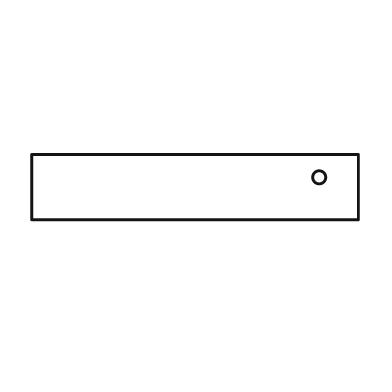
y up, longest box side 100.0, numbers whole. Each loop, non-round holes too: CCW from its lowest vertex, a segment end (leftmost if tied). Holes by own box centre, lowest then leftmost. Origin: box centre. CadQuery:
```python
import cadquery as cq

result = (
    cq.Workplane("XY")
    .moveTo(-50.0, -10.0)
    .lineTo(50.0, -10.0)
    .lineTo(50.0, 10.0)
    .lineTo(-50.0, 10.0)
    .close()
    .moveTo(38.0, 3.0)
    .circle(2.0)
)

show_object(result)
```